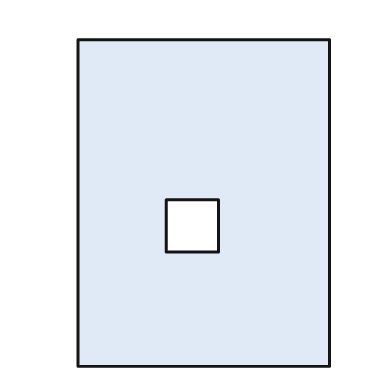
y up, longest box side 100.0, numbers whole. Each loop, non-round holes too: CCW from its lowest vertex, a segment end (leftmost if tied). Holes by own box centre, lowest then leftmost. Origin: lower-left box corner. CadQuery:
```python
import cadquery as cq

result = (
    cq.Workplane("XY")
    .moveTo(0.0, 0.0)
    .lineTo(77.0, 0.0)
    .lineTo(77.0, 100.0)
    .lineTo(0.0, 100.0)
    .close()
    .moveTo(27.0, 35.0)
    .lineTo(43.0, 35.0)
    .lineTo(43.0, 51.0)
    .lineTo(27.0, 51.0)
    .close()
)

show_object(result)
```